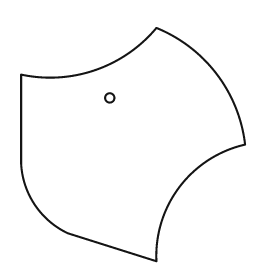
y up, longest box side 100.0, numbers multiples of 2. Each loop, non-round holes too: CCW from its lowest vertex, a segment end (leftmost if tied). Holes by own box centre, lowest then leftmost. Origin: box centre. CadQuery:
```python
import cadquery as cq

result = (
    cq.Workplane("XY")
    .moveTo(10.0, -50.0)
    .threePointArc((20.0, -18.0), (48.0, 0.0))
    .threePointArc((36.0, 30.0), (10.0, 50.0))
    .threePointArc((-16.0, 32.0), (-48.0, 30.0))
    .lineTo(-48.0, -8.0)
    .threePointArc((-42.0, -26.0), (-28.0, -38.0))
    .close()
    .moveTo(-10.0, 20.0)
    .circle(2.0)
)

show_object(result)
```